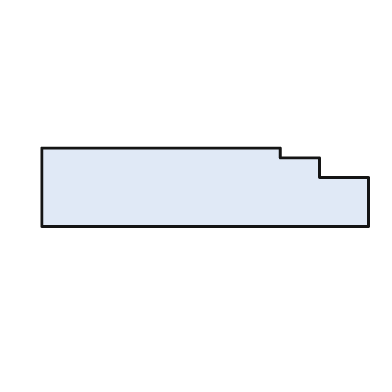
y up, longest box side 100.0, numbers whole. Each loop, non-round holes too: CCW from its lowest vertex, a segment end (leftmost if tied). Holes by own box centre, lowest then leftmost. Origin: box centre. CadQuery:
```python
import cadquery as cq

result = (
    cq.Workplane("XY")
    .moveTo(-50.0, -12.0)
    .lineTo(50.0, -12.0)
    .lineTo(50.0, 3.0)
    .lineTo(35.0, 3.0)
    .lineTo(35.0, 9.0)
    .lineTo(23.0, 9.0)
    .lineTo(23.0, 12.0)
    .lineTo(-50.0, 12.0)
    .close()
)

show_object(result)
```